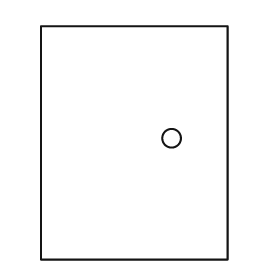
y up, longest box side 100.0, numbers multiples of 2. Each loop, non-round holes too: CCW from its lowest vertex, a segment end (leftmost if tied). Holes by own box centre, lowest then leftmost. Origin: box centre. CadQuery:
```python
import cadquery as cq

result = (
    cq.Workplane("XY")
    .moveTo(-40.0, -50.0)
    .lineTo(40.0, -50.0)
    .lineTo(40.0, 50.0)
    .lineTo(-40.0, 50.0)
    .close()
    .moveTo(16.0, 2.0)
    .circle(4.0)
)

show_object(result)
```